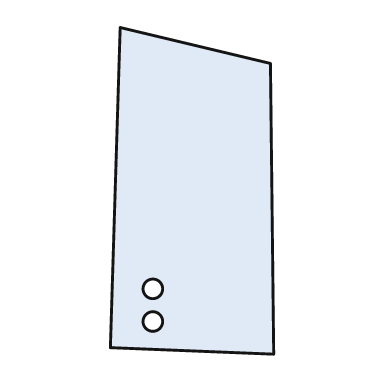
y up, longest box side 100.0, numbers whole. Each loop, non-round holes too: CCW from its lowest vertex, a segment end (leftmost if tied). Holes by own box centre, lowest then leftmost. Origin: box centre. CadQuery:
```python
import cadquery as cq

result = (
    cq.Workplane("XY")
    .moveTo(25.0, -50.0)
    .lineTo(24.0, 39.0)
    .lineTo(-22.0, 50.0)
    .lineTo(-25.0, -48.0)
    .close()
    .moveTo(-12.0, -40.0)
    .circle(3.0)
    .moveTo(-12.0, -30.0)
    .circle(3.0)
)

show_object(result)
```